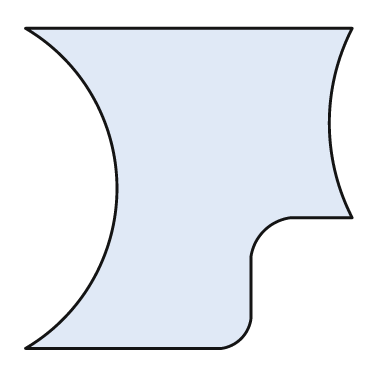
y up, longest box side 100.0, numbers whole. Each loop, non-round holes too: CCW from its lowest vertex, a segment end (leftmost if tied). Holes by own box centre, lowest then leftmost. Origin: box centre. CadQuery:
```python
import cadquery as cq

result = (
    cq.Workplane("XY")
    .moveTo(-50.0, -49.0)
    .lineTo(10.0, -49.0)
    .threePointArc((16.0, -46.0), (19.0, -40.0))
    .lineTo(19.0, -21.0)
    .threePointArc((23.0, -13.0), (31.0, -9.0))
    .lineTo(50.0, -9.0)
    .threePointArc((43.0, 20.0), (50.0, 49.0))
    .lineTo(-50.0, 49.0)
    .threePointArc((-22.0, 0.0), (-50.0, -49.0))
    .close()
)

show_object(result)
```